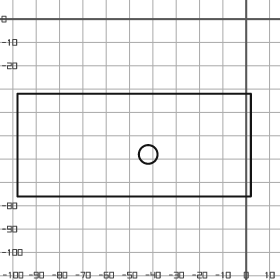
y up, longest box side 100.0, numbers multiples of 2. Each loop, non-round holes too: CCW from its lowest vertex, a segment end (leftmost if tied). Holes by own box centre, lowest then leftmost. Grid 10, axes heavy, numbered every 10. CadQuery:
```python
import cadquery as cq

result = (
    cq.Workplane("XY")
    .moveTo(-98.0, -76.0)
    .lineTo(2.0, -76.0)
    .lineTo(2.0, -32.0)
    .lineTo(-98.0, -32.0)
    .close()
    .moveTo(-42.0, -58.0)
    .circle(4.0)
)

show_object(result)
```